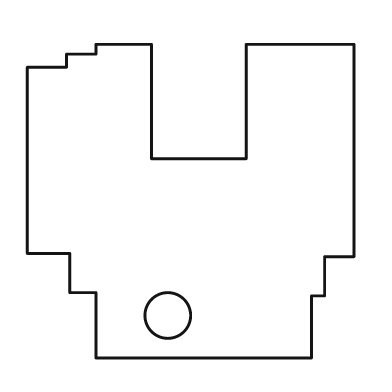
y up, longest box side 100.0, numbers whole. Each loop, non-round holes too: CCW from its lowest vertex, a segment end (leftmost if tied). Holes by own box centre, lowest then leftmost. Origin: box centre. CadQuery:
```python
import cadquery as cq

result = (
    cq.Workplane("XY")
    .moveTo(-29.0, -48.0)
    .lineTo(37.0, -48.0)
    .lineTo(37.0, -29.0)
    .lineTo(41.0, -29.0)
    .lineTo(41.0, -17.0)
    .lineTo(50.0, -17.0)
    .lineTo(50.0, 48.0)
    .lineTo(17.0, 48.0)
    .lineTo(17.0, 13.0)
    .lineTo(-12.0, 13.0)
    .lineTo(-12.0, 48.0)
    .lineTo(-29.0, 48.0)
    .lineTo(-29.0, 45.0)
    .lineTo(-38.0, 45.0)
    .lineTo(-38.0, 41.0)
    .lineTo(-50.0, 41.0)
    .lineTo(-50.0, -16.0)
    .lineTo(-37.0, -16.0)
    .lineTo(-37.0, -28.0)
    .lineTo(-29.0, -28.0)
    .close()
    .moveTo(-7.0, -35.0)
    .circle(7.0)
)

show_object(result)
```